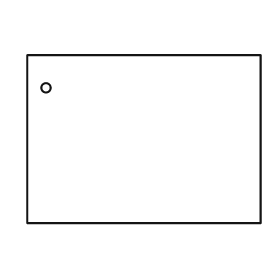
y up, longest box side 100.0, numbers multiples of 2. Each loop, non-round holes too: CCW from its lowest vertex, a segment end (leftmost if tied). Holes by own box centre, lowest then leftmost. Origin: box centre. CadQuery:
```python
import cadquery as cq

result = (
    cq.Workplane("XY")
    .moveTo(-50.0, -36.0)
    .lineTo(50.0, -36.0)
    .lineTo(50.0, 36.0)
    .lineTo(-50.0, 36.0)
    .close()
    .moveTo(-42.0, 22.0)
    .circle(2.0)
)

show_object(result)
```